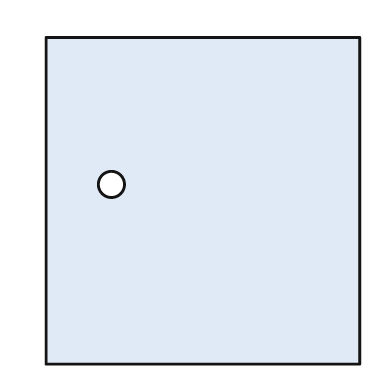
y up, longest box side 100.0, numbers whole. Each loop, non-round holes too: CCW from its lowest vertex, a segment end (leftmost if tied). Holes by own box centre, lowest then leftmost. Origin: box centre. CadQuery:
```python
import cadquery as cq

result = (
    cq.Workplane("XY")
    .moveTo(-48.0, -50.0)
    .lineTo(48.0, -50.0)
    .lineTo(48.0, 50.0)
    .lineTo(-48.0, 50.0)
    .close()
    .moveTo(-28.0, 5.0)
    .circle(4.0)
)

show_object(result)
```